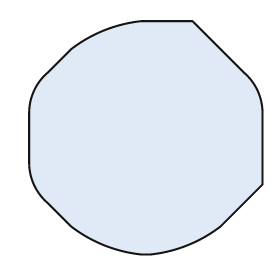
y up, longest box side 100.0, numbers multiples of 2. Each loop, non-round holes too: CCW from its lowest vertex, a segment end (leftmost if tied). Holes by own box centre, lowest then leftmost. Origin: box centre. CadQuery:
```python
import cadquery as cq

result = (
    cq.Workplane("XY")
    .moveTo(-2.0, -50.0)
    .lineTo(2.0, -50.0)
    .threePointArc((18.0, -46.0), (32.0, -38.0))
    .lineTo(50.0, -20.0)
    .lineTo(50.0, 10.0)
    .threePointArc((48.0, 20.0), (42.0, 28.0))
    .lineTo(20.0, 50.0)
    .lineTo(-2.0, 50.0)
    .threePointArc((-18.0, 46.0), (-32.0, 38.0))
    .lineTo(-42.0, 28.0)
    .threePointArc((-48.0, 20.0), (-50.0, 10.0))
    .lineTo(-50.0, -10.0)
    .threePointArc((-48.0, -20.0), (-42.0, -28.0))
    .lineTo(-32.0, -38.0)
    .threePointArc((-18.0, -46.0), (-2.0, -50.0))
    .close()
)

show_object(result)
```